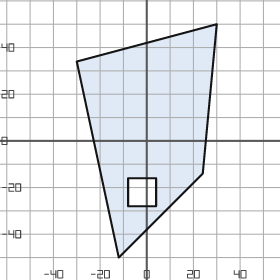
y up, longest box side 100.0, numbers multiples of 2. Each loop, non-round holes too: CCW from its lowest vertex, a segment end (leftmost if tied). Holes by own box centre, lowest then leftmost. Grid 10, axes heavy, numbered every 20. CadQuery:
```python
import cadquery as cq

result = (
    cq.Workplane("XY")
    .moveTo(-12.0, -50.0)
    .lineTo(24.0, -14.0)
    .lineTo(30.0, 50.0)
    .lineTo(-30.0, 34.0)
    .close()
    .moveTo(-8.0, -28.0)
    .lineTo(4.0, -28.0)
    .lineTo(4.0, -16.0)
    .lineTo(-8.0, -16.0)
    .close()
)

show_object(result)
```